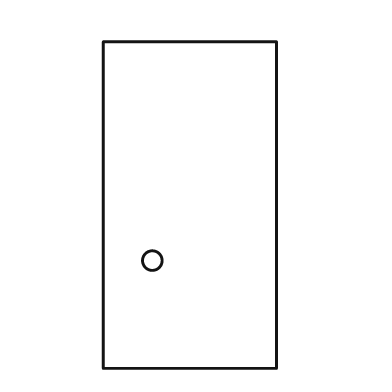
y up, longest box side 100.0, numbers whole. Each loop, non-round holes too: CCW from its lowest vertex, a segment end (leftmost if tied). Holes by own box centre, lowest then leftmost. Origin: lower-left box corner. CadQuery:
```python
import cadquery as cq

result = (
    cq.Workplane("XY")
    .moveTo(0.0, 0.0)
    .lineTo(53.0, 0.0)
    .lineTo(53.0, 100.0)
    .lineTo(0.0, 100.0)
    .close()
    .moveTo(15.0, 33.0)
    .circle(3.0)
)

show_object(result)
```